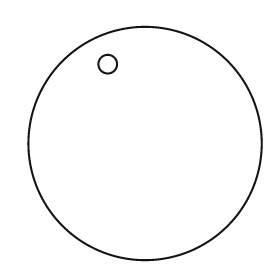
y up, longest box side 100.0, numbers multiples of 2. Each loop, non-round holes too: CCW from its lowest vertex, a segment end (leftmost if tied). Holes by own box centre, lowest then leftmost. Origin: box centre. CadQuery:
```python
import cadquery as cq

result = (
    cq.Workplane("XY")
    .moveTo(0.0, 0.0)
    .circle(50.0)
    .moveTo(-16.0, 34.0)
    .circle(4.0)
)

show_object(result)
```